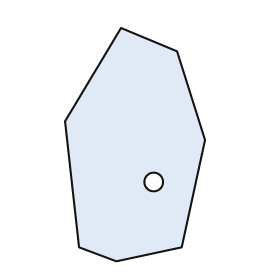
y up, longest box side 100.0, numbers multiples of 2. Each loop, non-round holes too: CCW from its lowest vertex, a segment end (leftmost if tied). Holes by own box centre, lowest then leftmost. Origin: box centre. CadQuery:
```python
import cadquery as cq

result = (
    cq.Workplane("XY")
    .moveTo(-8.0, -50.0)
    .lineTo(20.0, -44.0)
    .lineTo(30.0, 2.0)
    .lineTo(18.0, 40.0)
    .lineTo(-6.0, 50.0)
    .lineTo(-30.0, 10.0)
    .lineTo(-24.0, -44.0)
    .close()
    .moveTo(8.0, -16.0)
    .circle(4.0)
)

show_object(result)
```